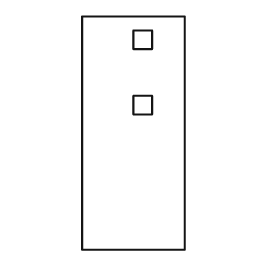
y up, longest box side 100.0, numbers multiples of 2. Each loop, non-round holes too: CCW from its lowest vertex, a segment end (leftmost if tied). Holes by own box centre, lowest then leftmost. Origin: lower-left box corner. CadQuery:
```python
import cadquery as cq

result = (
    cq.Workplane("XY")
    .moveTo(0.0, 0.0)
    .lineTo(44.0, 0.0)
    .lineTo(44.0, 100.0)
    .lineTo(0.0, 100.0)
    .close()
    .moveTo(22.0, 58.0)
    .lineTo(30.0, 58.0)
    .lineTo(30.0, 66.0)
    .lineTo(22.0, 66.0)
    .close()
    .moveTo(22.0, 86.0)
    .lineTo(30.0, 86.0)
    .lineTo(30.0, 94.0)
    .lineTo(22.0, 94.0)
    .close()
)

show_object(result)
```